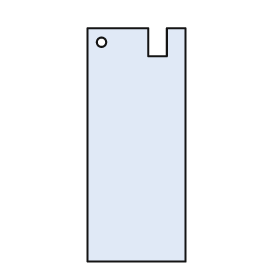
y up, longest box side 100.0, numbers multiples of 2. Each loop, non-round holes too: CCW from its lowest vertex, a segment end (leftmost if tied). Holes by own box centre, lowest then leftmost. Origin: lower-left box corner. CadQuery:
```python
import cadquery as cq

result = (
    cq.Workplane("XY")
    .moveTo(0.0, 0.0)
    .lineTo(42.0, 0.0)
    .lineTo(42.0, 100.0)
    .lineTo(34.0, 100.0)
    .lineTo(34.0, 88.0)
    .lineTo(26.0, 88.0)
    .lineTo(26.0, 100.0)
    .lineTo(0.0, 100.0)
    .close()
    .moveTo(6.0, 94.0)
    .circle(2.0)
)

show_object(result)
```